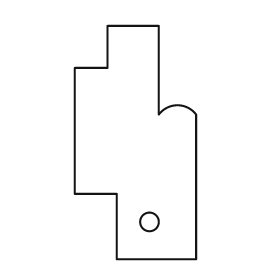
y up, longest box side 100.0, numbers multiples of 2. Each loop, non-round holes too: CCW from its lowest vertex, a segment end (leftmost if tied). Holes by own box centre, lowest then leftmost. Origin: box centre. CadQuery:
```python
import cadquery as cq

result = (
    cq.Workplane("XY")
    .moveTo(-8.0, -50.0)
    .lineTo(26.0, -50.0)
    .lineTo(26.0, 12.0)
    .threePointArc((18.0, 16.0), (10.0, 12.0))
    .lineTo(10.0, 50.0)
    .lineTo(-12.0, 50.0)
    .lineTo(-12.0, 32.0)
    .lineTo(-26.0, 32.0)
    .lineTo(-26.0, -22.0)
    .lineTo(-8.0, -22.0)
    .close()
    .moveTo(6.0, -34.0)
    .circle(4.0)
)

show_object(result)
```